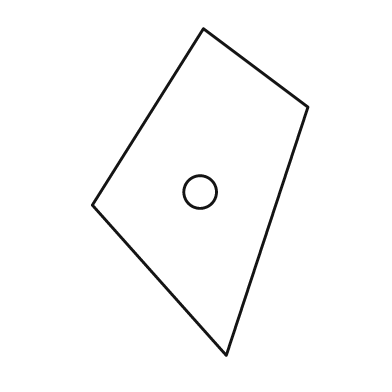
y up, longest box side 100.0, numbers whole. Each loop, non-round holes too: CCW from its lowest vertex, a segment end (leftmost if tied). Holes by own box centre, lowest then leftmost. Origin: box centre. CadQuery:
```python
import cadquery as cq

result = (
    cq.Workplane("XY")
    .moveTo(8.0, -50.0)
    .lineTo(33.0, 26.0)
    .lineTo(1.0, 50.0)
    .lineTo(-33.0, -4.0)
    .close()
    .moveTo(0.0, 0.0)
    .circle(5.0)
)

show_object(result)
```